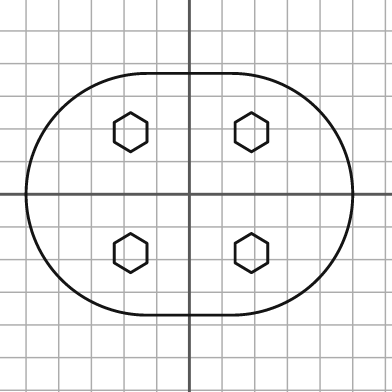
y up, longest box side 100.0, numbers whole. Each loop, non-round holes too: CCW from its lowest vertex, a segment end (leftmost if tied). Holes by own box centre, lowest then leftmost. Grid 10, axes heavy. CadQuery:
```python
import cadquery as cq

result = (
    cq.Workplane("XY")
    .moveTo(-13.0, -37.0)
    .lineTo(13.0, -37.0)
    .threePointArc((50.0, 0.0), (13.0, 37.0))
    .lineTo(-13.0, 37.0)
    .threePointArc((-50.0, 0.0), (-13.0, -37.0))
    .close()
    .moveTo(-18.0, -24.0)
    .lineTo(-13.0, -21.0)
    .lineTo(-13.0, -15.0)
    .lineTo(-18.0, -12.0)
    .lineTo(-23.0, -15.0)
    .lineTo(-23.0, -21.0)
    .close()
    .moveTo(19.0, -24.0)
    .lineTo(24.0, -21.0)
    .lineTo(24.0, -15.0)
    .lineTo(19.0, -12.0)
    .lineTo(14.0, -15.0)
    .lineTo(14.0, -21.0)
    .close()
    .moveTo(-18.0, 13.0)
    .lineTo(-13.0, 16.0)
    .lineTo(-13.0, 22.0)
    .lineTo(-18.0, 25.0)
    .lineTo(-23.0, 22.0)
    .lineTo(-23.0, 16.0)
    .close()
    .moveTo(19.0, 13.0)
    .lineTo(24.0, 16.0)
    .lineTo(24.0, 22.0)
    .lineTo(19.0, 25.0)
    .lineTo(14.0, 22.0)
    .lineTo(14.0, 16.0)
    .close()
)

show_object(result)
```